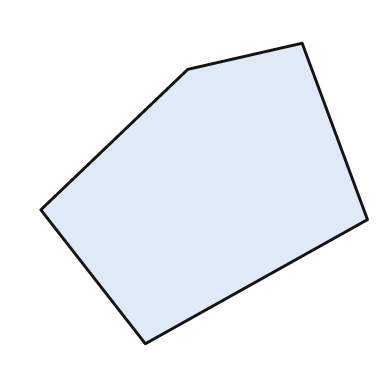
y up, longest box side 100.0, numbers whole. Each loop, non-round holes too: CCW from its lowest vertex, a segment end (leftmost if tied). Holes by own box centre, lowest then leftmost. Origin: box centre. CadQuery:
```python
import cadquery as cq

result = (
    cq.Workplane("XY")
    .moveTo(-18.0, -46.0)
    .lineTo(50.0, -8.0)
    .lineTo(30.0, 46.0)
    .lineTo(-5.0, 38.0)
    .lineTo(-50.0, -5.0)
    .close()
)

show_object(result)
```